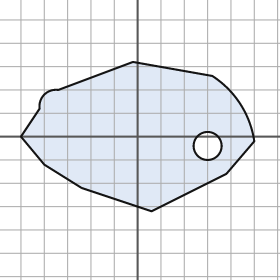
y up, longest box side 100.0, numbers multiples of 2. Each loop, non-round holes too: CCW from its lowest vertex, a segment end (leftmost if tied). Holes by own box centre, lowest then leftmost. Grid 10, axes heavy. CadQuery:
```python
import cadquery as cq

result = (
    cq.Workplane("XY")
    .moveTo(6.0, -32.0)
    .lineTo(38.0, -16.0)
    .lineTo(50.0, -2.0)
    .threePointArc((44.0, 14.0), (32.0, 26.0))
    .lineTo(-2.0, 32.0)
    .lineTo(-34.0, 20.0)
    .threePointArc((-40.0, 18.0), (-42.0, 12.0))
    .lineTo(-50.0, 0.0)
    .lineTo(-40.0, -12.0)
    .lineTo(-24.0, -22.0)
    .close()
    .moveTo(30.0, -4.0)
    .circle(6.0)
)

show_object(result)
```